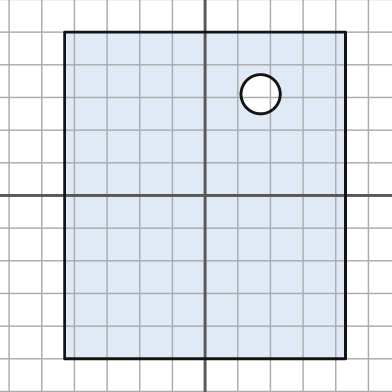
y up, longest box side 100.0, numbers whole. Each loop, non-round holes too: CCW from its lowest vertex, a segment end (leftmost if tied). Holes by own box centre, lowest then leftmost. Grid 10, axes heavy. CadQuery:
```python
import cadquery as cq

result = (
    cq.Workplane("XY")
    .moveTo(-43.0, -50.0)
    .lineTo(43.0, -50.0)
    .lineTo(43.0, 50.0)
    .lineTo(-43.0, 50.0)
    .close()
    .moveTo(17.0, 31.0)
    .circle(6.0)
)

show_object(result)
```